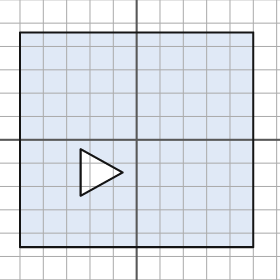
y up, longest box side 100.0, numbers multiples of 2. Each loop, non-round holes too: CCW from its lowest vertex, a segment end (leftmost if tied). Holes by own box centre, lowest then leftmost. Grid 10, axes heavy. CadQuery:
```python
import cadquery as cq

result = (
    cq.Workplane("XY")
    .moveTo(-50.0, -46.0)
    .lineTo(50.0, -46.0)
    .lineTo(50.0, 46.0)
    .lineTo(-50.0, 46.0)
    .close()
    .moveTo(-24.0, -24.0)
    .lineTo(-6.0, -14.0)
    .lineTo(-24.0, -4.0)
    .close()
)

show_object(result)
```